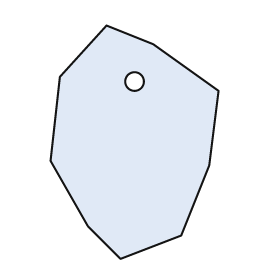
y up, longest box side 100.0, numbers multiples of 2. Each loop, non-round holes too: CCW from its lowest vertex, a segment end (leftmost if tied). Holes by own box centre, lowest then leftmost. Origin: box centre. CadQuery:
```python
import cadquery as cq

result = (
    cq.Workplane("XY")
    .moveTo(-6.0, -50.0)
    .lineTo(20.0, -40.0)
    .lineTo(32.0, -10.0)
    .lineTo(36.0, 22.0)
    .lineTo(8.0, 42.0)
    .lineTo(-12.0, 50.0)
    .lineTo(-32.0, 28.0)
    .lineTo(-36.0, -8.0)
    .lineTo(-20.0, -36.0)
    .close()
    .moveTo(0.0, 26.0)
    .circle(4.0)
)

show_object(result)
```